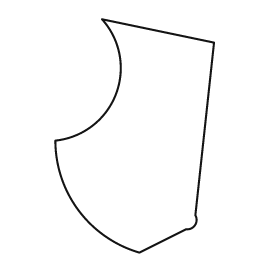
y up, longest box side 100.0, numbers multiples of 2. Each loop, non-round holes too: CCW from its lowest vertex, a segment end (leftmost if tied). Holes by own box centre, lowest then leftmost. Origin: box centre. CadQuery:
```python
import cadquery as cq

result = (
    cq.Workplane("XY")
    .moveTo(2.0, -50.0)
    .lineTo(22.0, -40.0)
    .threePointArc((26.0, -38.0), (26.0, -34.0))
    .lineTo(34.0, 40.0)
    .lineTo(-14.0, 50.0)
    .threePointArc((-8.0, 18.0), (-34.0, -2.0))
    .threePointArc((-24.0, -32.0), (2.0, -50.0))
    .close()
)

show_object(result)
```